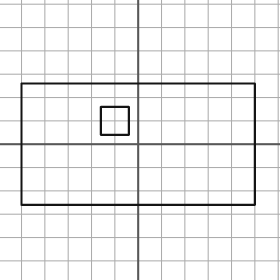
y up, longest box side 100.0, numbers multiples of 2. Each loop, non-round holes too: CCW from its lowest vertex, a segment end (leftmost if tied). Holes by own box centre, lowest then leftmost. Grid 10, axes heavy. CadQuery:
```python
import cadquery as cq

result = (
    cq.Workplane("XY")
    .moveTo(-50.0, -26.0)
    .lineTo(50.0, -26.0)
    .lineTo(50.0, 26.0)
    .lineTo(-50.0, 26.0)
    .close()
    .moveTo(-16.0, 4.0)
    .lineTo(-4.0, 4.0)
    .lineTo(-4.0, 16.0)
    .lineTo(-16.0, 16.0)
    .close()
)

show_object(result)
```